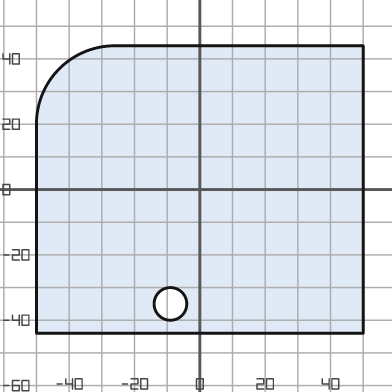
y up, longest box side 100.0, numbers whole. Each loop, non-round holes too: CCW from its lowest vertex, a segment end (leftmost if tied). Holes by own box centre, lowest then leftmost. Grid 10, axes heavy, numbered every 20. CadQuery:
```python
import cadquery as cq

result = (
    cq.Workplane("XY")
    .moveTo(-50.0, -44.0)
    .lineTo(50.0, -44.0)
    .lineTo(50.0, 44.0)
    .lineTo(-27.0, 44.0)
    .threePointArc((-43.0, 37.0), (-50.0, 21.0))
    .close()
    .moveTo(-9.0, -35.0)
    .circle(5.0)
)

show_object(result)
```